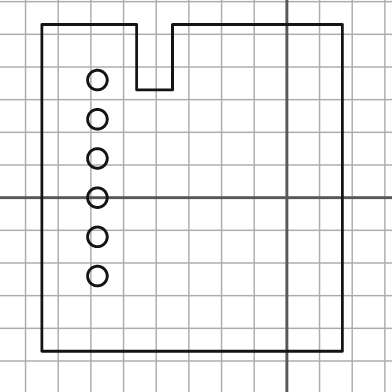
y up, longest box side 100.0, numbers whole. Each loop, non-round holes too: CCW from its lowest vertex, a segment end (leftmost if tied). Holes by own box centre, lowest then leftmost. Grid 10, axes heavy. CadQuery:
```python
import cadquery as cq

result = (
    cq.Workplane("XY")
    .moveTo(-75.0, -47.0)
    .lineTo(17.0, -47.0)
    .lineTo(17.0, 53.0)
    .lineTo(-35.0, 53.0)
    .lineTo(-35.0, 33.0)
    .lineTo(-46.0, 33.0)
    .lineTo(-46.0, 53.0)
    .lineTo(-75.0, 53.0)
    .close()
    .moveTo(-58.0, -24.0)
    .circle(3.0)
    .moveTo(-58.0, -12.0)
    .circle(3.0)
    .moveTo(-58.0, 0.0)
    .circle(3.0)
    .moveTo(-58.0, 12.0)
    .circle(3.0)
    .moveTo(-58.0, 24.0)
    .circle(3.0)
    .moveTo(-58.0, 36.0)
    .circle(3.0)
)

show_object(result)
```